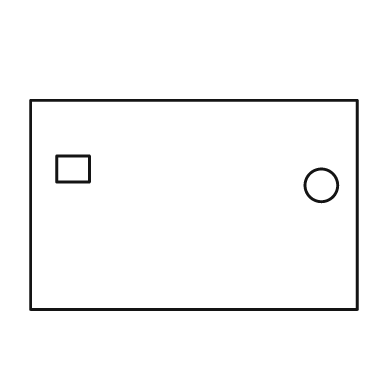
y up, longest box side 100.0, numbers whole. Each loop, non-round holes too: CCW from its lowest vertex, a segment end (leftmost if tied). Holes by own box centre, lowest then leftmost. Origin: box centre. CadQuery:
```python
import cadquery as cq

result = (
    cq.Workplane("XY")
    .moveTo(-50.0, -32.0)
    .lineTo(50.0, -32.0)
    .lineTo(50.0, 32.0)
    .lineTo(-50.0, 32.0)
    .close()
    .moveTo(39.0, 6.0)
    .circle(5.0)
    .moveTo(-42.0, 7.0)
    .lineTo(-32.0, 7.0)
    .lineTo(-32.0, 15.0)
    .lineTo(-42.0, 15.0)
    .close()
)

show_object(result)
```